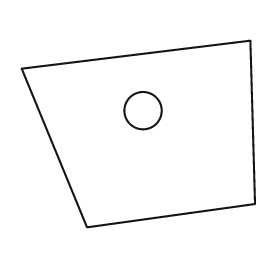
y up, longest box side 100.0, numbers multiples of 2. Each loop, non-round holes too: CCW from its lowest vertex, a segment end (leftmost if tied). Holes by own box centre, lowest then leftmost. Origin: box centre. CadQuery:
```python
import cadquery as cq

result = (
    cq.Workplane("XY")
    .moveTo(-22.0, -40.0)
    .lineTo(50.0, -30.0)
    .lineTo(48.0, 40.0)
    .lineTo(-50.0, 28.0)
    .close()
    .moveTo(2.0, 10.0)
    .circle(8.0)
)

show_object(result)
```